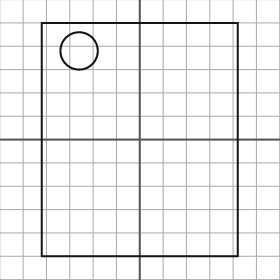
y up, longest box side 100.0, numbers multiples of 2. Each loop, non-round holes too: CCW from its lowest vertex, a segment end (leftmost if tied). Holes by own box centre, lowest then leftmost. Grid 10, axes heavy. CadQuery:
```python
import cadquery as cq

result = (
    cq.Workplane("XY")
    .moveTo(-42.0, -50.0)
    .lineTo(42.0, -50.0)
    .lineTo(42.0, 50.0)
    .lineTo(-42.0, 50.0)
    .close()
    .moveTo(-26.0, 38.0)
    .circle(8.0)
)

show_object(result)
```